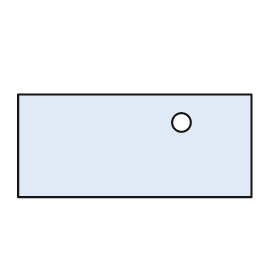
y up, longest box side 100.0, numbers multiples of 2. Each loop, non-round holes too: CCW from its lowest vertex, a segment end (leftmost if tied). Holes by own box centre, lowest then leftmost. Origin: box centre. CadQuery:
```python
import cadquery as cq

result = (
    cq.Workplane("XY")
    .moveTo(-50.0, -22.0)
    .lineTo(50.0, -22.0)
    .lineTo(50.0, 22.0)
    .lineTo(-50.0, 22.0)
    .close()
    .moveTo(20.0, 10.0)
    .circle(4.0)
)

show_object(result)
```